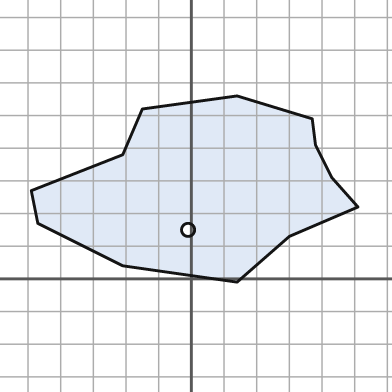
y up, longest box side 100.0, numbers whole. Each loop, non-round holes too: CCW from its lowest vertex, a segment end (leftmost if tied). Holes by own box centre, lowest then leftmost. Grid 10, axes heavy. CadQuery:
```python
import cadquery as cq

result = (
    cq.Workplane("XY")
    .moveTo(14.0, -1.0)
    .lineTo(30.0, 13.0)
    .lineTo(51.0, 22.0)
    .lineTo(43.0, 31.0)
    .lineTo(38.0, 41.0)
    .lineTo(37.0, 49.0)
    .lineTo(14.0, 56.0)
    .lineTo(-15.0, 52.0)
    .lineTo(-21.0, 38.0)
    .lineTo(-49.0, 27.0)
    .lineTo(-47.0, 17.0)
    .lineTo(-21.0, 4.0)
    .close()
    .moveTo(-1.0, 15.0)
    .circle(2.0)
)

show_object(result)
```